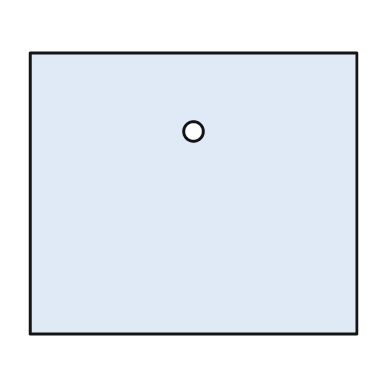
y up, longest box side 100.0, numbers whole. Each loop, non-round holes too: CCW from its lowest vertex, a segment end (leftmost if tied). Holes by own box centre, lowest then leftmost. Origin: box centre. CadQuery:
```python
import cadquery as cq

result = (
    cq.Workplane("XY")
    .moveTo(-50.0, -43.0)
    .lineTo(50.0, -43.0)
    .lineTo(50.0, 43.0)
    .lineTo(-50.0, 43.0)
    .close()
    .moveTo(0.0, 19.0)
    .circle(3.0)
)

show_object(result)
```